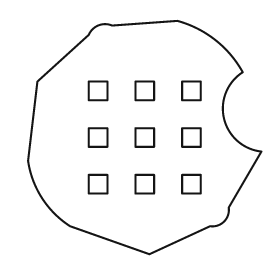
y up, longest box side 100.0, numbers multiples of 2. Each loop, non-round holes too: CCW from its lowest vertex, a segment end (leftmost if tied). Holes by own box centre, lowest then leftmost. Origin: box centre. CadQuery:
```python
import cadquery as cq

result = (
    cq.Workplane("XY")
    .moveTo(2.0, -50.0)
    .lineTo(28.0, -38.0)
    .threePointArc((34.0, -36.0), (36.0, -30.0))
    .lineTo(50.0, -6.0)
    .threePointArc((34.0, 8.0), (42.0, 28.0))
    .threePointArc((30.0, 42.0), (14.0, 50.0))
    .lineTo(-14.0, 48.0)
    .threePointArc((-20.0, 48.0), (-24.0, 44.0))
    .lineTo(-46.0, 24.0)
    .lineTo(-50.0, -10.0)
    .threePointArc((-44.0, -26.0), (-32.0, -38.0))
    .close()
    .moveTo(-24.0, -24.0)
    .lineTo(-16.0, -24.0)
    .lineTo(-16.0, -16.0)
    .lineTo(-24.0, -16.0)
    .close()
    .moveTo(-4.0, -24.0)
    .lineTo(4.0, -24.0)
    .lineTo(4.0, -16.0)
    .lineTo(-4.0, -16.0)
    .close()
    .moveTo(16.0, -24.0)
    .lineTo(24.0, -24.0)
    .lineTo(24.0, -16.0)
    .lineTo(16.0, -16.0)
    .close()
    .moveTo(-24.0, -4.0)
    .lineTo(-16.0, -4.0)
    .lineTo(-16.0, 4.0)
    .lineTo(-24.0, 4.0)
    .close()
    .moveTo(-4.0, -4.0)
    .lineTo(4.0, -4.0)
    .lineTo(4.0, 4.0)
    .lineTo(-4.0, 4.0)
    .close()
    .moveTo(16.0, -4.0)
    .lineTo(24.0, -4.0)
    .lineTo(24.0, 4.0)
    .lineTo(16.0, 4.0)
    .close()
    .moveTo(-24.0, 16.0)
    .lineTo(-16.0, 16.0)
    .lineTo(-16.0, 24.0)
    .lineTo(-24.0, 24.0)
    .close()
    .moveTo(-4.0, 16.0)
    .lineTo(4.0, 16.0)
    .lineTo(4.0, 24.0)
    .lineTo(-4.0, 24.0)
    .close()
    .moveTo(16.0, 16.0)
    .lineTo(24.0, 16.0)
    .lineTo(24.0, 24.0)
    .lineTo(16.0, 24.0)
    .close()
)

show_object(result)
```